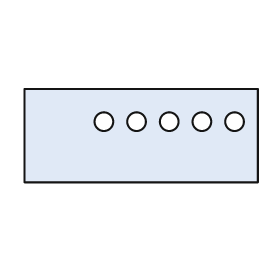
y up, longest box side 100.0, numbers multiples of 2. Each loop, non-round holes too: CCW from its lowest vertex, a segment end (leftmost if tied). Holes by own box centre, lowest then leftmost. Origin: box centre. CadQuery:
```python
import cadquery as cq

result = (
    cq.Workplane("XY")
    .moveTo(-50.0, -20.0)
    .lineTo(50.0, -20.0)
    .lineTo(50.0, 20.0)
    .lineTo(-50.0, 20.0)
    .close()
    .moveTo(-16.0, 6.0)
    .circle(4.0)
    .moveTo(-2.0, 6.0)
    .circle(4.0)
    .moveTo(12.0, 6.0)
    .circle(4.0)
    .moveTo(26.0, 6.0)
    .circle(4.0)
    .moveTo(40.0, 6.0)
    .circle(4.0)
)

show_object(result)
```